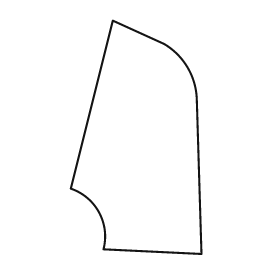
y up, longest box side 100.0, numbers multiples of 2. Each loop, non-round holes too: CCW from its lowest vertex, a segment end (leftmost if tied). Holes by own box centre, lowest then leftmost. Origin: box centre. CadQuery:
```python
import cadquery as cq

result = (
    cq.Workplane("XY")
    .moveTo(28.0, -50.0)
    .lineTo(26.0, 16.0)
    .threePointArc((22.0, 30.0), (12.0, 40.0))
    .lineTo(-10.0, 50.0)
    .lineTo(-28.0, -22.0)
    .threePointArc((-16.0, -32.0), (-14.0, -48.0))
    .close()
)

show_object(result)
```